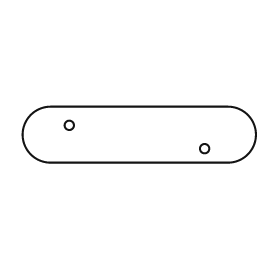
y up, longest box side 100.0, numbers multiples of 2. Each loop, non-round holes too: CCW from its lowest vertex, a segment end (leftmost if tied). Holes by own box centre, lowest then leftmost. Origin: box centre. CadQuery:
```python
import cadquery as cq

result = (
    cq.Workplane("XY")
    .moveTo(-38.0, -12.0)
    .lineTo(38.0, -12.0)
    .threePointArc((50.0, 0.0), (38.0, 12.0))
    .lineTo(-38.0, 12.0)
    .threePointArc((-50.0, 0.0), (-38.0, -12.0))
    .close()
    .moveTo(28.0, -6.0)
    .circle(2.0)
    .moveTo(-30.0, 4.0)
    .circle(2.0)
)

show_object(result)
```